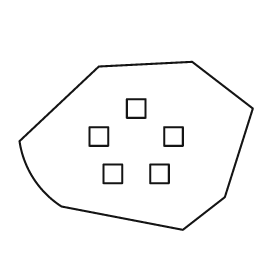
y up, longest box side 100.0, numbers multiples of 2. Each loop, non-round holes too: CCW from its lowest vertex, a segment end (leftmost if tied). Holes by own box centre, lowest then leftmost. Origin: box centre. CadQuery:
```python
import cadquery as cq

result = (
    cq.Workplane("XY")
    .moveTo(20.0, -36.0)
    .lineTo(38.0, -22.0)
    .lineTo(50.0, 16.0)
    .lineTo(24.0, 36.0)
    .lineTo(-16.0, 34.0)
    .lineTo(-50.0, 2.0)
    .threePointArc((-44.0, -14.0), (-32.0, -26.0))
    .close()
    .moveTo(-14.0, -16.0)
    .lineTo(-6.0, -16.0)
    .lineTo(-6.0, -8.0)
    .lineTo(-14.0, -8.0)
    .close()
    .moveTo(6.0, -16.0)
    .lineTo(14.0, -16.0)
    .lineTo(14.0, -8.0)
    .lineTo(6.0, -8.0)
    .close()
    .moveTo(-20.0, 0.0)
    .lineTo(-12.0, 0.0)
    .lineTo(-12.0, 8.0)
    .lineTo(-20.0, 8.0)
    .close()
    .moveTo(12.0, 0.0)
    .lineTo(20.0, 0.0)
    .lineTo(20.0, 8.0)
    .lineTo(12.0, 8.0)
    .close()
    .moveTo(-4.0, 12.0)
    .lineTo(4.0, 12.0)
    .lineTo(4.0, 20.0)
    .lineTo(-4.0, 20.0)
    .close()
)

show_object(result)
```